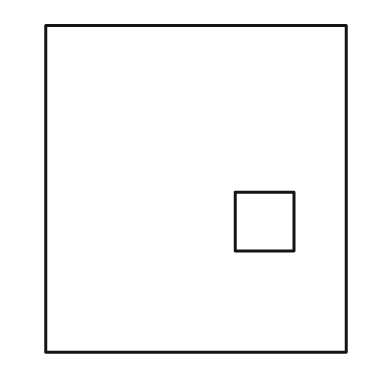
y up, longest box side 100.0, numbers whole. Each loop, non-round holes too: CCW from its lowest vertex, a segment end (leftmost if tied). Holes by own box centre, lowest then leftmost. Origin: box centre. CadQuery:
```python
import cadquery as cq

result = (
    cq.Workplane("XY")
    .moveTo(-46.0, -50.0)
    .lineTo(46.0, -50.0)
    .lineTo(46.0, 50.0)
    .lineTo(-46.0, 50.0)
    .close()
    .moveTo(12.0, -19.0)
    .lineTo(30.0, -19.0)
    .lineTo(30.0, -1.0)
    .lineTo(12.0, -1.0)
    .close()
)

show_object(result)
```